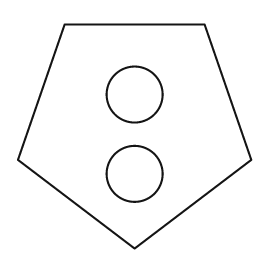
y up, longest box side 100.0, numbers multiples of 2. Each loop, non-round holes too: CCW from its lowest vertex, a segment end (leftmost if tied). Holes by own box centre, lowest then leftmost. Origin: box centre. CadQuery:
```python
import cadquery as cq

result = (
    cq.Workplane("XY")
    .moveTo(0.0, -48.0)
    .lineTo(50.0, -10.0)
    .lineTo(30.0, 48.0)
    .lineTo(-30.0, 48.0)
    .lineTo(-50.0, -10.0)
    .close()
    .moveTo(0.0, -16.0)
    .circle(12.0)
    .moveTo(0.0, 18.0)
    .circle(12.0)
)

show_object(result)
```